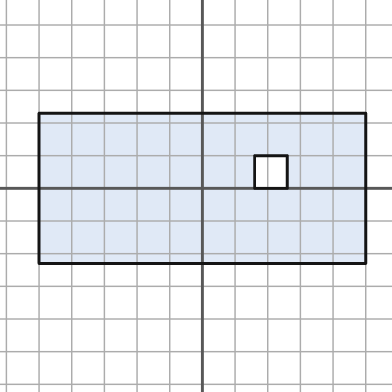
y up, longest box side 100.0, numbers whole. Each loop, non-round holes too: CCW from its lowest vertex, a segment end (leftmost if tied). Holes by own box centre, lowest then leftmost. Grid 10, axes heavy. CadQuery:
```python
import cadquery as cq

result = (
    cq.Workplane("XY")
    .moveTo(-50.0, -23.0)
    .lineTo(50.0, -23.0)
    .lineTo(50.0, 23.0)
    .lineTo(-50.0, 23.0)
    .close()
    .moveTo(16.0, 0.0)
    .lineTo(26.0, 0.0)
    .lineTo(26.0, 10.0)
    .lineTo(16.0, 10.0)
    .close()
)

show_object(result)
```